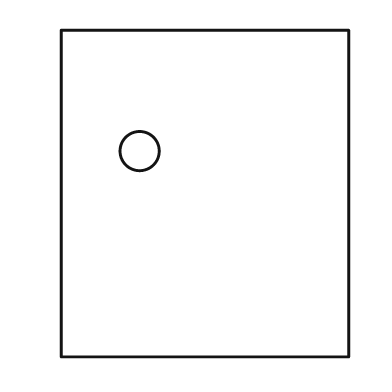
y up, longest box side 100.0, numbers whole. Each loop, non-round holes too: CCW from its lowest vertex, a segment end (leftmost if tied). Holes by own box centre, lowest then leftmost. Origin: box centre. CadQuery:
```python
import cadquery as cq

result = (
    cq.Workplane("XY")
    .moveTo(-44.0, -50.0)
    .lineTo(44.0, -50.0)
    .lineTo(44.0, 50.0)
    .lineTo(-44.0, 50.0)
    .close()
    .moveTo(-20.0, 13.0)
    .circle(6.0)
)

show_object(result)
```